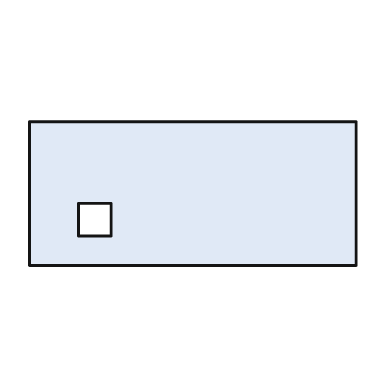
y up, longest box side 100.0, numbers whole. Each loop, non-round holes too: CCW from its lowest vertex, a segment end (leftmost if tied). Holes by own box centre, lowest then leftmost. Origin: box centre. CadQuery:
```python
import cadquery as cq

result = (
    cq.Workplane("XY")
    .moveTo(-50.0, -22.0)
    .lineTo(50.0, -22.0)
    .lineTo(50.0, 22.0)
    .lineTo(-50.0, 22.0)
    .close()
    .moveTo(-35.0, -13.0)
    .lineTo(-25.0, -13.0)
    .lineTo(-25.0, -3.0)
    .lineTo(-35.0, -3.0)
    .close()
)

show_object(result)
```